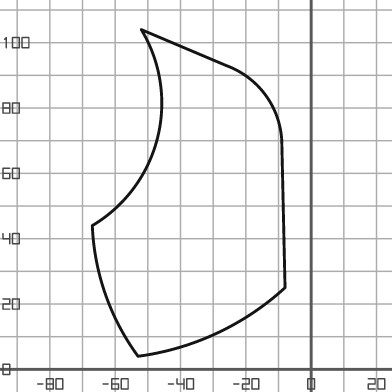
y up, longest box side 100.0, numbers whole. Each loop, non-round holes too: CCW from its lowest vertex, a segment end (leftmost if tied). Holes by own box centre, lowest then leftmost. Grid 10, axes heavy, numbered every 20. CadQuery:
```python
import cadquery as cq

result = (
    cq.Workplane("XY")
    .moveTo(-53.0, 4.0)
    .threePointArc((-29.0, 11.0), (-8.0, 25.0))
    .lineTo(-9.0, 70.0)
    .threePointArc((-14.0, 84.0), (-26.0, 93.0))
    .lineTo(-52.0, 104.0)
    .threePointArc((-47.0, 71.0), (-67.0, 44.0))
    .threePointArc((-63.0, 23.0), (-53.0, 4.0))
    .close()
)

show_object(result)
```